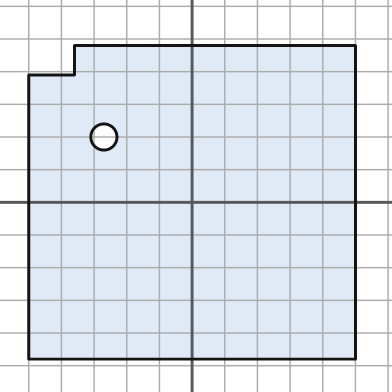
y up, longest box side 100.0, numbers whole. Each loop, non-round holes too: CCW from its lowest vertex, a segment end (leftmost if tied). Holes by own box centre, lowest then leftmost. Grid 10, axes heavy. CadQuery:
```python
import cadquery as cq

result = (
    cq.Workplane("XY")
    .moveTo(-50.0, -48.0)
    .lineTo(50.0, -48.0)
    .lineTo(50.0, 48.0)
    .lineTo(-36.0, 48.0)
    .lineTo(-36.0, 39.0)
    .lineTo(-50.0, 39.0)
    .close()
    .moveTo(-27.0, 20.0)
    .circle(4.0)
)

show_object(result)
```